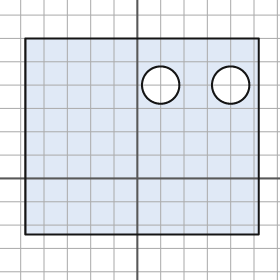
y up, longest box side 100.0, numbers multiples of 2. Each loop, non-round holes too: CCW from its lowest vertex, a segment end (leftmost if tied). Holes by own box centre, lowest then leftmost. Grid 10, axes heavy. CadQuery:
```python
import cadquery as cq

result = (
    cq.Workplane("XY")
    .moveTo(-48.0, -24.0)
    .lineTo(52.0, -24.0)
    .lineTo(52.0, 60.0)
    .lineTo(-48.0, 60.0)
    .close()
    .moveTo(10.0, 40.0)
    .circle(8.0)
    .moveTo(40.0, 40.0)
    .circle(8.0)
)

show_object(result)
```